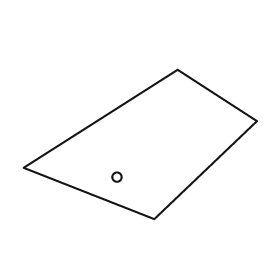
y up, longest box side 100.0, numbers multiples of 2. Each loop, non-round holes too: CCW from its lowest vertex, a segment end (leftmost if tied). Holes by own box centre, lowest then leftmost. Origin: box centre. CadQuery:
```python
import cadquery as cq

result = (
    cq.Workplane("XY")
    .moveTo(6.0, -32.0)
    .lineTo(50.0, 10.0)
    .lineTo(16.0, 32.0)
    .lineTo(-50.0, -10.0)
    .close()
    .moveTo(-10.0, -14.0)
    .circle(2.0)
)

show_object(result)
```